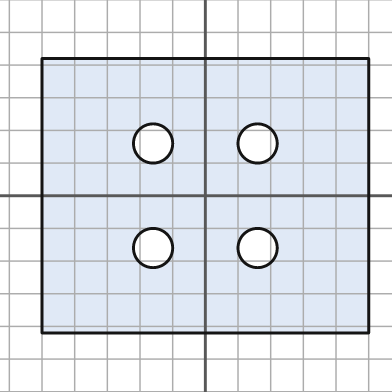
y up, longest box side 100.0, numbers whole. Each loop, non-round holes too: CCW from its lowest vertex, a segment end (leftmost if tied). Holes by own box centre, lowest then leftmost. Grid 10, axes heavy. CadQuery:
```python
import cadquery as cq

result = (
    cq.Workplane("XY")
    .moveTo(-50.0, -42.0)
    .lineTo(50.0, -42.0)
    .lineTo(50.0, 42.0)
    .lineTo(-50.0, 42.0)
    .close()
    .moveTo(-16.0, -16.0)
    .circle(6.0)
    .moveTo(16.0, -16.0)
    .circle(6.0)
    .moveTo(-16.0, 16.0)
    .circle(6.0)
    .moveTo(16.0, 16.0)
    .circle(6.0)
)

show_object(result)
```